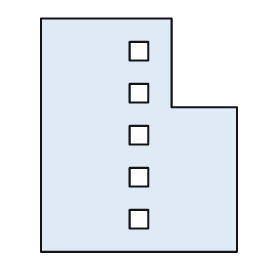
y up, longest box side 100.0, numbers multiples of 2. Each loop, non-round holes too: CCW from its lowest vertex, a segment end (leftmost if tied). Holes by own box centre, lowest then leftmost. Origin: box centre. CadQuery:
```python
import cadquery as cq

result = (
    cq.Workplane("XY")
    .moveTo(-42.0, -50.0)
    .lineTo(42.0, -50.0)
    .lineTo(42.0, 12.0)
    .lineTo(14.0, 12.0)
    .lineTo(14.0, 50.0)
    .lineTo(-42.0, 50.0)
    .close()
    .moveTo(-4.0, -40.0)
    .lineTo(4.0, -40.0)
    .lineTo(4.0, -32.0)
    .lineTo(-4.0, -32.0)
    .close()
    .moveTo(-4.0, -22.0)
    .lineTo(4.0, -22.0)
    .lineTo(4.0, -14.0)
    .lineTo(-4.0, -14.0)
    .close()
    .moveTo(-4.0, -4.0)
    .lineTo(4.0, -4.0)
    .lineTo(4.0, 4.0)
    .lineTo(-4.0, 4.0)
    .close()
    .moveTo(-4.0, 14.0)
    .lineTo(4.0, 14.0)
    .lineTo(4.0, 22.0)
    .lineTo(-4.0, 22.0)
    .close()
    .moveTo(-4.0, 32.0)
    .lineTo(4.0, 32.0)
    .lineTo(4.0, 40.0)
    .lineTo(-4.0, 40.0)
    .close()
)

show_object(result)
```